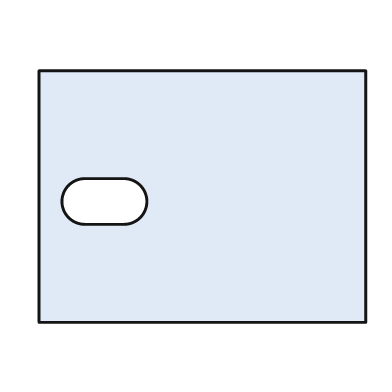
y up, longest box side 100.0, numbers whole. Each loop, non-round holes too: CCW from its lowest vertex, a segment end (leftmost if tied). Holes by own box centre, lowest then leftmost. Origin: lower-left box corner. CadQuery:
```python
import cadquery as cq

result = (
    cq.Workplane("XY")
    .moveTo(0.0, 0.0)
    .lineTo(100.0, 0.0)
    .lineTo(100.0, 77.0)
    .lineTo(0.0, 77.0)
    .close()
    .moveTo(14.0, 30.0)
    .lineTo(26.0, 30.0)
    .threePointArc((33.0, 37.0), (26.0, 44.0))
    .lineTo(14.0, 44.0)
    .threePointArc((7.0, 37.0), (14.0, 30.0))
    .close()
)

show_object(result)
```